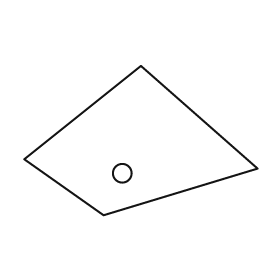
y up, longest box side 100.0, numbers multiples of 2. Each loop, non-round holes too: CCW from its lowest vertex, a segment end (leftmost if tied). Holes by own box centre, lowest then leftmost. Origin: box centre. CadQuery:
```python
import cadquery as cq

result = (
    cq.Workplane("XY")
    .moveTo(-16.0, -32.0)
    .lineTo(50.0, -12.0)
    .lineTo(0.0, 32.0)
    .lineTo(-50.0, -8.0)
    .close()
    .moveTo(-8.0, -14.0)
    .circle(4.0)
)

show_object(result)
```